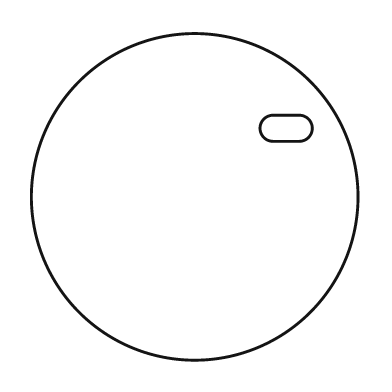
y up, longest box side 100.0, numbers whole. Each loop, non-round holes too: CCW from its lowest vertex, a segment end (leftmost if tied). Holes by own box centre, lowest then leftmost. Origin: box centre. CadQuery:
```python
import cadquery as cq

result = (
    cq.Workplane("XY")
    .moveTo(0.0, 0.0)
    .circle(50.0)
    .moveTo(24.0, 17.0)
    .lineTo(32.0, 17.0)
    .threePointArc((36.0, 21.0), (32.0, 25.0))
    .lineTo(24.0, 25.0)
    .threePointArc((20.0, 21.0), (24.0, 17.0))
    .close()
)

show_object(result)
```